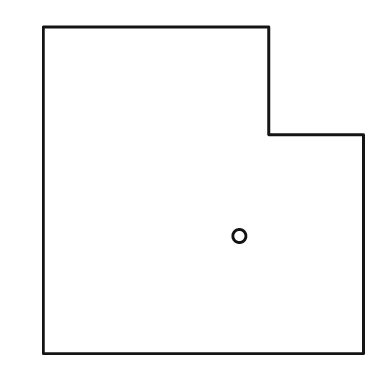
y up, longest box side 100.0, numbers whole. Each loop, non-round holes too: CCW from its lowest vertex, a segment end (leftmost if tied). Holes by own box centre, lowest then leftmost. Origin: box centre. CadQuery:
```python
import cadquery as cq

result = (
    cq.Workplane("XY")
    .moveTo(-49.0, -50.0)
    .lineTo(49.0, -50.0)
    .lineTo(49.0, 17.0)
    .lineTo(20.0, 17.0)
    .lineTo(20.0, 50.0)
    .lineTo(-49.0, 50.0)
    .close()
    .moveTo(11.0, -14.0)
    .circle(2.0)
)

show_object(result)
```